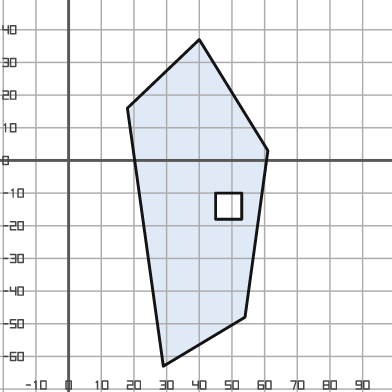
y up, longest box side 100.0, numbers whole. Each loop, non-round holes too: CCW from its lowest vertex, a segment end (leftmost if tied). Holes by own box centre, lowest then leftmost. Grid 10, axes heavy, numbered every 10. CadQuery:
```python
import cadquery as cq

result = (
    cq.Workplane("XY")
    .moveTo(29.0, -63.0)
    .lineTo(54.0, -48.0)
    .lineTo(61.0, 3.0)
    .lineTo(40.0, 37.0)
    .lineTo(18.0, 16.0)
    .close()
    .moveTo(45.0, -18.0)
    .lineTo(53.0, -18.0)
    .lineTo(53.0, -10.0)
    .lineTo(45.0, -10.0)
    .close()
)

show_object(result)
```